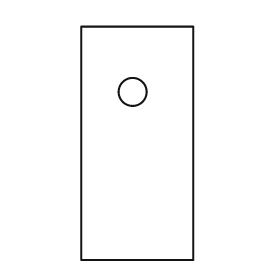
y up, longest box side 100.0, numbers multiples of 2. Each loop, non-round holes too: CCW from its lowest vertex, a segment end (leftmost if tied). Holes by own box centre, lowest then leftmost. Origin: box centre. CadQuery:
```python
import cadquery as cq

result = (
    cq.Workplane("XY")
    .moveTo(-24.0, -50.0)
    .lineTo(24.0, -50.0)
    .lineTo(24.0, 50.0)
    .lineTo(-24.0, 50.0)
    .close()
    .moveTo(-2.0, 22.0)
    .circle(6.0)
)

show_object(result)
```